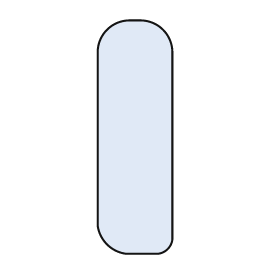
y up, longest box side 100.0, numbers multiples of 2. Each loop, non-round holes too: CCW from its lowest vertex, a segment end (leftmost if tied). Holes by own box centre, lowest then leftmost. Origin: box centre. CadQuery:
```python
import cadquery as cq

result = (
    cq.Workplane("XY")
    .moveTo(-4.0, -50.0)
    .lineTo(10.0, -50.0)
    .threePointArc((14.0, -48.0), (16.0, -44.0))
    .lineTo(16.0, 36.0)
    .threePointArc((12.0, 46.0), (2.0, 50.0))
    .lineTo(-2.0, 50.0)
    .threePointArc((-12.0, 46.0), (-16.0, 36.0))
    .lineTo(-16.0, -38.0)
    .threePointArc((-12.0, -46.0), (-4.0, -50.0))
    .close()
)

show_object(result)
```